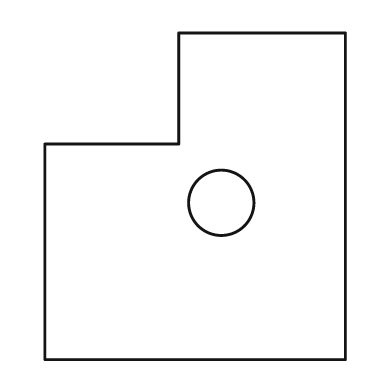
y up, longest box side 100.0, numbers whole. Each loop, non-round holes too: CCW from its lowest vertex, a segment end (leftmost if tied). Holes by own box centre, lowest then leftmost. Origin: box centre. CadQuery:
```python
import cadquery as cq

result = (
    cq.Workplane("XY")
    .moveTo(-46.0, -50.0)
    .lineTo(46.0, -50.0)
    .lineTo(46.0, 50.0)
    .lineTo(-5.0, 50.0)
    .lineTo(-5.0, 16.0)
    .lineTo(-46.0, 16.0)
    .close()
    .moveTo(8.0, -2.0)
    .circle(10.0)
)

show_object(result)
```